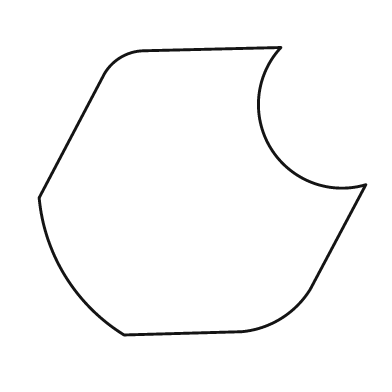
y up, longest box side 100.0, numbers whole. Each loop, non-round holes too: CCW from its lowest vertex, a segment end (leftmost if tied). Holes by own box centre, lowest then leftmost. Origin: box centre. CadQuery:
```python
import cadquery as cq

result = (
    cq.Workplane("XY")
    .moveTo(-24.0, -44.0)
    .lineTo(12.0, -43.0)
    .threePointArc((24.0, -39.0), (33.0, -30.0))
    .lineTo(50.0, 2.0)
    .threePointArc((21.0, 13.0), (24.0, 44.0))
    .lineTo(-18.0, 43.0)
    .threePointArc((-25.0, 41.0), (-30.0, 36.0))
    .lineTo(-50.0, -2.0)
    .threePointArc((-42.0, -26.0), (-24.0, -44.0))
    .close()
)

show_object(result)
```